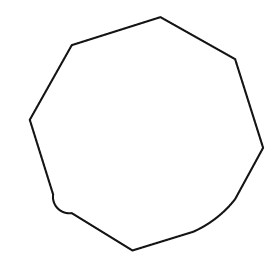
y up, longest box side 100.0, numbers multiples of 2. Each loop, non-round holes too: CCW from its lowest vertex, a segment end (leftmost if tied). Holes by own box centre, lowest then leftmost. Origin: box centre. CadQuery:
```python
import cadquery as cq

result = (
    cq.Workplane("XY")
    .moveTo(-6.0, -50.0)
    .lineTo(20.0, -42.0)
    .threePointArc((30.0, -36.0), (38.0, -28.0))
    .lineTo(50.0, -6.0)
    .lineTo(38.0, 32.0)
    .lineTo(6.0, 50.0)
    .lineTo(-32.0, 38.0)
    .lineTo(-50.0, 6.0)
    .lineTo(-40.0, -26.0)
    .threePointArc((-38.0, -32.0), (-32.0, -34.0))
    .close()
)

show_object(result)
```